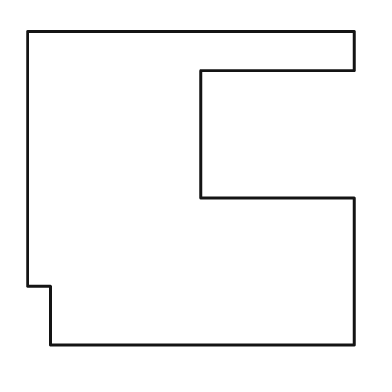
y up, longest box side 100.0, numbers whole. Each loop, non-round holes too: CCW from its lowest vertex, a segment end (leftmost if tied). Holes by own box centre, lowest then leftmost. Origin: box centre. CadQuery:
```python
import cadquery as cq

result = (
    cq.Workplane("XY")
    .moveTo(-43.0, -48.0)
    .lineTo(50.0, -48.0)
    .lineTo(50.0, -3.0)
    .lineTo(3.0, -3.0)
    .lineTo(3.0, 36.0)
    .lineTo(50.0, 36.0)
    .lineTo(50.0, 48.0)
    .lineTo(-50.0, 48.0)
    .lineTo(-50.0, -30.0)
    .lineTo(-43.0, -30.0)
    .close()
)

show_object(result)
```